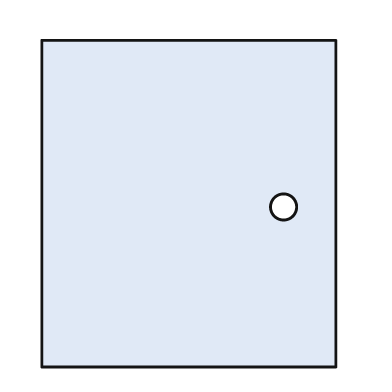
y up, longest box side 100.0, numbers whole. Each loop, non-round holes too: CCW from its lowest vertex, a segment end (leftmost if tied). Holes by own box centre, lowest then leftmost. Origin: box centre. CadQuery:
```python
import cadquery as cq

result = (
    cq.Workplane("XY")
    .moveTo(-45.0, -50.0)
    .lineTo(45.0, -50.0)
    .lineTo(45.0, 50.0)
    .lineTo(-45.0, 50.0)
    .close()
    .moveTo(29.0, -1.0)
    .circle(4.0)
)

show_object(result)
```